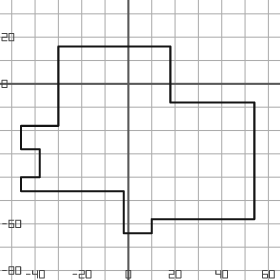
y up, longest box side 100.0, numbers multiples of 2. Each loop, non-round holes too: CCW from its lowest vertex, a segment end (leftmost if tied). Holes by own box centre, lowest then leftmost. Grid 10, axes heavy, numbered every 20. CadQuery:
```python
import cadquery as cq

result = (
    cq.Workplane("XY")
    .moveTo(-2.0, -64.0)
    .lineTo(10.0, -64.0)
    .lineTo(10.0, -58.0)
    .lineTo(54.0, -58.0)
    .lineTo(54.0, -8.0)
    .lineTo(18.0, -8.0)
    .lineTo(18.0, 16.0)
    .lineTo(-30.0, 16.0)
    .lineTo(-30.0, -18.0)
    .lineTo(-46.0, -18.0)
    .lineTo(-46.0, -28.0)
    .lineTo(-38.0, -28.0)
    .lineTo(-38.0, -40.0)
    .lineTo(-46.0, -40.0)
    .lineTo(-46.0, -46.0)
    .lineTo(-2.0, -46.0)
    .close()
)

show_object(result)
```